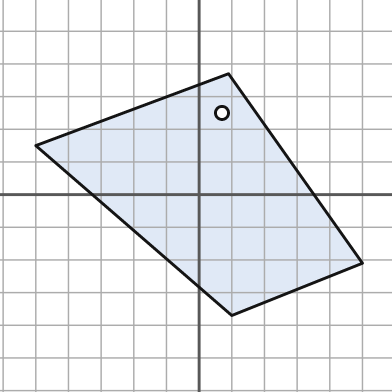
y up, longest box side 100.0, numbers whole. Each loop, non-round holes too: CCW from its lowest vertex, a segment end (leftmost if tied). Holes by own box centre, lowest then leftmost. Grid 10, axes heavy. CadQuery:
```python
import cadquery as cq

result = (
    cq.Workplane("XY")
    .moveTo(10.0, -37.0)
    .lineTo(50.0, -21.0)
    .lineTo(9.0, 37.0)
    .lineTo(-50.0, 15.0)
    .close()
    .moveTo(7.0, 25.0)
    .circle(2.0)
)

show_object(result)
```